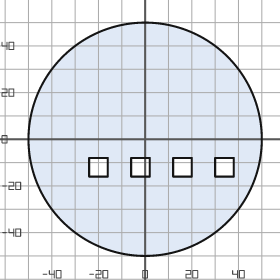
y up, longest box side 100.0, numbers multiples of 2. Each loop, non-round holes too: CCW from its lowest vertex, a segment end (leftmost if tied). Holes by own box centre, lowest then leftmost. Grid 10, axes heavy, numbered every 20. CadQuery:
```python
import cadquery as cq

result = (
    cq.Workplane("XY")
    .moveTo(0.0, 0.0)
    .circle(50.0)
    .moveTo(-24.0, -16.0)
    .lineTo(-16.0, -16.0)
    .lineTo(-16.0, -8.0)
    .lineTo(-24.0, -8.0)
    .close()
    .moveTo(-6.0, -16.0)
    .lineTo(2.0, -16.0)
    .lineTo(2.0, -8.0)
    .lineTo(-6.0, -8.0)
    .close()
    .moveTo(12.0, -16.0)
    .lineTo(20.0, -16.0)
    .lineTo(20.0, -8.0)
    .lineTo(12.0, -8.0)
    .close()
    .moveTo(30.0, -16.0)
    .lineTo(38.0, -16.0)
    .lineTo(38.0, -8.0)
    .lineTo(30.0, -8.0)
    .close()
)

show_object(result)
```